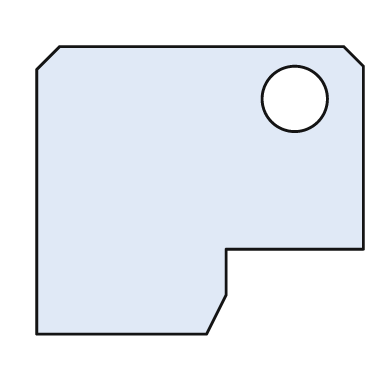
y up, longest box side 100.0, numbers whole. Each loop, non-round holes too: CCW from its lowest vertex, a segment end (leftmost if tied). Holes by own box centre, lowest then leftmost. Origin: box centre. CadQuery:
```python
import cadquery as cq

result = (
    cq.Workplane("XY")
    .moveTo(-50.0, -44.0)
    .lineTo(2.0, -44.0)
    .lineTo(8.0, -32.0)
    .lineTo(8.0, -18.0)
    .lineTo(50.0, -18.0)
    .lineTo(50.0, 38.0)
    .lineTo(44.0, 44.0)
    .lineTo(-43.0, 44.0)
    .lineTo(-50.0, 37.0)
    .close()
    .moveTo(29.0, 28.0)
    .circle(10.0)
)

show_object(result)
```